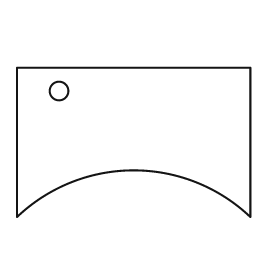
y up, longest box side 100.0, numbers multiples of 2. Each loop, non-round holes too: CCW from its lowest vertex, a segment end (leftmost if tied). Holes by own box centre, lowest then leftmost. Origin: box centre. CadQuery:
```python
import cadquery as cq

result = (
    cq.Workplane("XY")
    .moveTo(-50.0, -32.0)
    .threePointArc((0.0, -12.0), (50.0, -32.0))
    .lineTo(50.0, 32.0)
    .lineTo(-50.0, 32.0)
    .close()
    .moveTo(-32.0, 22.0)
    .circle(4.0)
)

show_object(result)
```